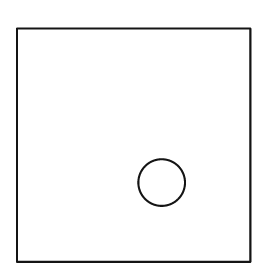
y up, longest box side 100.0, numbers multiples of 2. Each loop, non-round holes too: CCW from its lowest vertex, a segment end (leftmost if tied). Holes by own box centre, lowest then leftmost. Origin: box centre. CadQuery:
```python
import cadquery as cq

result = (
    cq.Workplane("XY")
    .moveTo(-50.0, -50.0)
    .lineTo(50.0, -50.0)
    .lineTo(50.0, 50.0)
    .lineTo(-50.0, 50.0)
    .close()
    .moveTo(12.0, -16.0)
    .circle(10.0)
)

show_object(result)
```